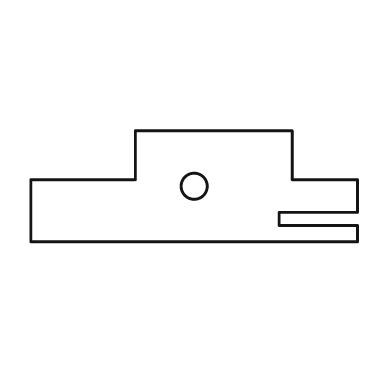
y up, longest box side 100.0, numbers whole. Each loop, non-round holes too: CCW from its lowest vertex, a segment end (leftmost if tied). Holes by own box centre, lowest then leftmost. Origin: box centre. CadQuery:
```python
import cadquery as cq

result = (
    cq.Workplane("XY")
    .moveTo(-50.0, -17.0)
    .lineTo(50.0, -17.0)
    .lineTo(50.0, -12.0)
    .lineTo(26.0, -12.0)
    .lineTo(26.0, -8.0)
    .lineTo(50.0, -8.0)
    .lineTo(50.0, 2.0)
    .lineTo(30.0, 2.0)
    .lineTo(30.0, 17.0)
    .lineTo(-18.0, 17.0)
    .lineTo(-18.0, 2.0)
    .lineTo(-50.0, 2.0)
    .close()
    .moveTo(0.0, 0.0)
    .circle(4.0)
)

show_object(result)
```